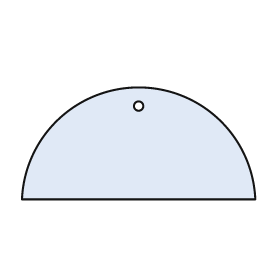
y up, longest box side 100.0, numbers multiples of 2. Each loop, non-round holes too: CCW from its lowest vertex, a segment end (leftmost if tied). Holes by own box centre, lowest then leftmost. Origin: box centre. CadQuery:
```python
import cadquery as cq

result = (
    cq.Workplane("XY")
    .moveTo(-50.0, -24.0)
    .lineTo(50.0, -24.0)
    .threePointArc((0.0, 24.0), (-50.0, -24.0))
    .close()
    .moveTo(0.0, 16.0)
    .circle(2.0)
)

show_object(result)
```